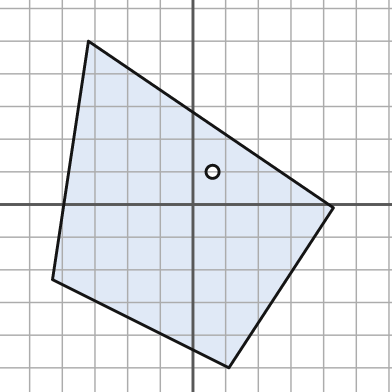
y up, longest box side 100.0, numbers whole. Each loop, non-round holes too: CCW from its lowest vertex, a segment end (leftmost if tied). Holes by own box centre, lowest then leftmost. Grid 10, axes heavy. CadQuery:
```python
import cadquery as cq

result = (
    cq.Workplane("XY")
    .moveTo(11.0, -50.0)
    .lineTo(43.0, -1.0)
    .lineTo(-32.0, 50.0)
    .lineTo(-43.0, -23.0)
    .close()
    .moveTo(6.0, 10.0)
    .circle(2.0)
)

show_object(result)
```